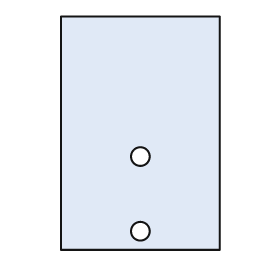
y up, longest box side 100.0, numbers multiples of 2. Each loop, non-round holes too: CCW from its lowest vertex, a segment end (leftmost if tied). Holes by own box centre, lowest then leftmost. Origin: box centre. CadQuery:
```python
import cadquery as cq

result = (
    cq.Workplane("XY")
    .moveTo(-34.0, -50.0)
    .lineTo(34.0, -50.0)
    .lineTo(34.0, 50.0)
    .lineTo(-34.0, 50.0)
    .close()
    .moveTo(0.0, -42.0)
    .circle(4.0)
    .moveTo(0.0, -10.0)
    .circle(4.0)
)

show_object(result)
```